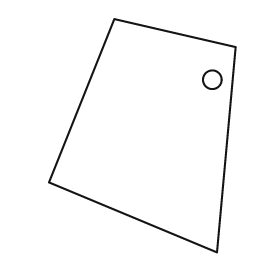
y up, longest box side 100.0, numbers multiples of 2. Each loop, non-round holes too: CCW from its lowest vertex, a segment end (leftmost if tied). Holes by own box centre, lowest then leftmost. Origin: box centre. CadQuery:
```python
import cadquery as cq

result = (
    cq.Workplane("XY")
    .moveTo(32.0, -50.0)
    .lineTo(40.0, 38.0)
    .lineTo(-12.0, 50.0)
    .lineTo(-40.0, -20.0)
    .close()
    .moveTo(30.0, 24.0)
    .circle(4.0)
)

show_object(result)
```